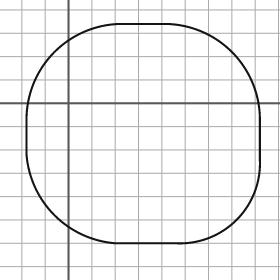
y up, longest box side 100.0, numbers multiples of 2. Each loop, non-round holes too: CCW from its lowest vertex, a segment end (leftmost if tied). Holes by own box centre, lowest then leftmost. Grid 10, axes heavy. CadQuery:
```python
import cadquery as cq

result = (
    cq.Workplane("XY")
    .moveTo(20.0, -60.0)
    .lineTo(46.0, -60.0)
    .threePointArc((72.0, -50.0), (82.0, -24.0))
    .lineTo(82.0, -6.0)
    .threePointArc((70.0, 22.0), (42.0, 34.0))
    .lineTo(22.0, 34.0)
    .threePointArc((-6.0, 22.0), (-18.0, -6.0))
    .lineTo(-18.0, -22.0)
    .threePointArc((-6.0, -48.0), (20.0, -60.0))
    .close()
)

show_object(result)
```